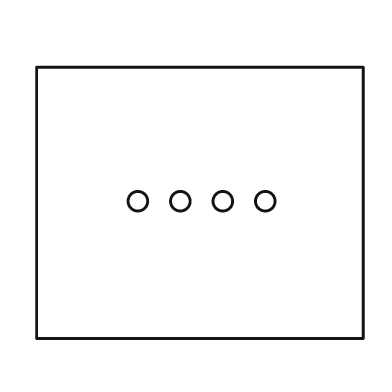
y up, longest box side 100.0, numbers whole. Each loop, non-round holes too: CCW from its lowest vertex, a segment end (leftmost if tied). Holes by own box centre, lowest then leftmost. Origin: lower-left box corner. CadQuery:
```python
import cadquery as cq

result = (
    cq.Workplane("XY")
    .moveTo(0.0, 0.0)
    .lineTo(100.0, 0.0)
    .lineTo(100.0, 83.0)
    .lineTo(0.0, 83.0)
    .close()
    .moveTo(31.0, 42.0)
    .circle(3.0)
    .moveTo(44.0, 42.0)
    .circle(3.0)
    .moveTo(57.0, 42.0)
    .circle(3.0)
    .moveTo(70.0, 42.0)
    .circle(3.0)
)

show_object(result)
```